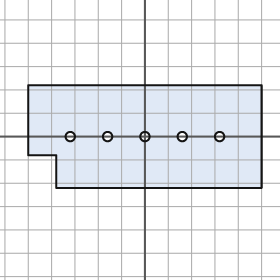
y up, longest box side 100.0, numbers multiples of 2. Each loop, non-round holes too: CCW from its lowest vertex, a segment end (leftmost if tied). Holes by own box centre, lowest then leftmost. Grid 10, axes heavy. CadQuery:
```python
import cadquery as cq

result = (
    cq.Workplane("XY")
    .moveTo(-38.0, -22.0)
    .lineTo(50.0, -22.0)
    .lineTo(50.0, 22.0)
    .lineTo(-50.0, 22.0)
    .lineTo(-50.0, -8.0)
    .lineTo(-38.0, -8.0)
    .close()
    .moveTo(-32.0, 0.0)
    .circle(2.0)
    .moveTo(-16.0, 0.0)
    .circle(2.0)
    .moveTo(0.0, 0.0)
    .circle(2.0)
    .moveTo(16.0, 0.0)
    .circle(2.0)
    .moveTo(32.0, 0.0)
    .circle(2.0)
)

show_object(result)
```